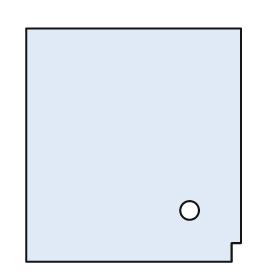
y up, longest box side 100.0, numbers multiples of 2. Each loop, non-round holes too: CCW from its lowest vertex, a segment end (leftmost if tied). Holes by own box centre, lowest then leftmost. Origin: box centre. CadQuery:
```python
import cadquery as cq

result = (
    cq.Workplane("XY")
    .moveTo(-46.0, -50.0)
    .lineTo(42.0, -50.0)
    .lineTo(42.0, -42.0)
    .lineTo(46.0, -42.0)
    .lineTo(46.0, 50.0)
    .lineTo(-46.0, 50.0)
    .close()
    .moveTo(24.0, -28.0)
    .circle(4.0)
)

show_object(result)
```